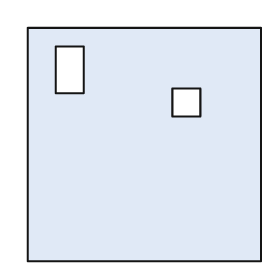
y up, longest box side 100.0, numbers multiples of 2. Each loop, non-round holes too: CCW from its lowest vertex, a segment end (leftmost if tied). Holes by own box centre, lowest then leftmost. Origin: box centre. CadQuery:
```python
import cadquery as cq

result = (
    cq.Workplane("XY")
    .moveTo(-50.0, -50.0)
    .lineTo(50.0, -50.0)
    .lineTo(50.0, 50.0)
    .lineTo(-50.0, 50.0)
    .close()
    .moveTo(12.0, 12.0)
    .lineTo(24.0, 12.0)
    .lineTo(24.0, 24.0)
    .lineTo(12.0, 24.0)
    .close()
    .moveTo(-38.0, 22.0)
    .lineTo(-26.0, 22.0)
    .lineTo(-26.0, 42.0)
    .lineTo(-38.0, 42.0)
    .close()
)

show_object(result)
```